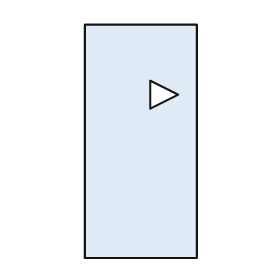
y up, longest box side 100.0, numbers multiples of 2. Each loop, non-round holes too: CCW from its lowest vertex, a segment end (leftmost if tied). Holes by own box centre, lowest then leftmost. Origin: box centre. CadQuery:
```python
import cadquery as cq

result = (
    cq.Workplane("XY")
    .moveTo(-24.0, -50.0)
    .lineTo(24.0, -50.0)
    .lineTo(24.0, 50.0)
    .lineTo(-24.0, 50.0)
    .close()
    .moveTo(4.0, 14.0)
    .lineTo(16.0, 20.0)
    .lineTo(4.0, 26.0)
    .close()
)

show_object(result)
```